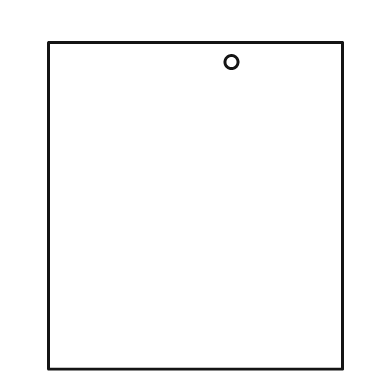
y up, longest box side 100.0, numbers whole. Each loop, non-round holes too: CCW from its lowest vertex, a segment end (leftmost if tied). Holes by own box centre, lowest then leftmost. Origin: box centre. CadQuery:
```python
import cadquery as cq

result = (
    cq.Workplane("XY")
    .moveTo(-45.0, -50.0)
    .lineTo(45.0, -50.0)
    .lineTo(45.0, 50.0)
    .lineTo(-45.0, 50.0)
    .close()
    .moveTo(11.0, 44.0)
    .circle(2.0)
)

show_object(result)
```